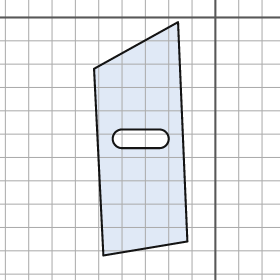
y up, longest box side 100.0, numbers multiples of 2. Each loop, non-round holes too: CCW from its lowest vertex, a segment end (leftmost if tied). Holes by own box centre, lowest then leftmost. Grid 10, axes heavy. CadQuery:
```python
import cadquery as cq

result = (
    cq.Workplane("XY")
    .moveTo(-48.0, -102.0)
    .lineTo(-12.0, -96.0)
    .lineTo(-16.0, -2.0)
    .lineTo(-52.0, -22.0)
    .close()
    .moveTo(-40.0, -56.0)
    .lineTo(-24.0, -56.0)
    .threePointArc((-20.0, -52.0), (-24.0, -48.0))
    .lineTo(-40.0, -48.0)
    .threePointArc((-44.0, -52.0), (-40.0, -56.0))
    .close()
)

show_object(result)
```